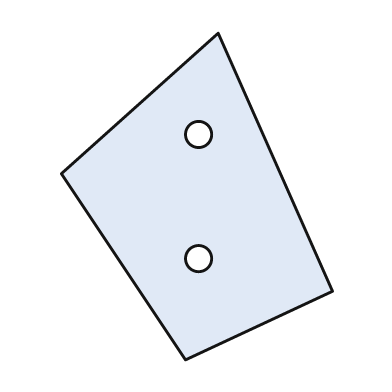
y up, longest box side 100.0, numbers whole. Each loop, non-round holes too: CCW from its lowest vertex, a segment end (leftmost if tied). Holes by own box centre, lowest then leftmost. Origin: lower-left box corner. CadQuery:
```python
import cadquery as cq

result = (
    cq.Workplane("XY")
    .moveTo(38.0, 0.0)
    .lineTo(83.0, 21.0)
    .lineTo(48.0, 100.0)
    .lineTo(0.0, 57.0)
    .close()
    .moveTo(42.0, 31.0)
    .circle(4.0)
    .moveTo(42.0, 69.0)
    .circle(4.0)
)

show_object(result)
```